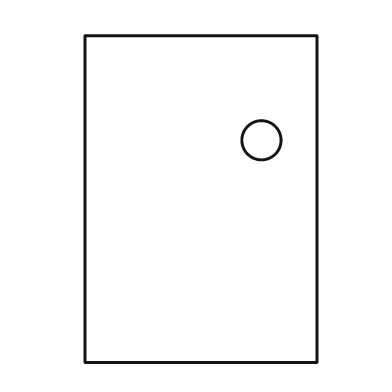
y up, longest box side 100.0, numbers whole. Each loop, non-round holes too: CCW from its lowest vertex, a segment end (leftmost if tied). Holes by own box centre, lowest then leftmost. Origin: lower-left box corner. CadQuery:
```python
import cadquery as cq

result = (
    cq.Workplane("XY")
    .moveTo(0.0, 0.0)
    .lineTo(71.0, 0.0)
    .lineTo(71.0, 100.0)
    .lineTo(0.0, 100.0)
    .close()
    .moveTo(54.0, 68.0)
    .circle(6.0)
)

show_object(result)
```